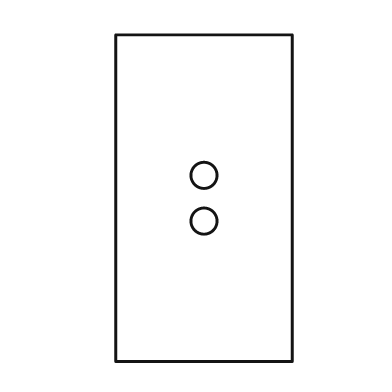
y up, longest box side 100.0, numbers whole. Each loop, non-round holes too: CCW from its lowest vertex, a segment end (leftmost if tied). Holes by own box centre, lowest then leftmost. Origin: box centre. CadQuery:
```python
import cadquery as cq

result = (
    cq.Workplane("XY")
    .moveTo(-27.0, -50.0)
    .lineTo(27.0, -50.0)
    .lineTo(27.0, 50.0)
    .lineTo(-27.0, 50.0)
    .close()
    .moveTo(0.0, -7.0)
    .circle(4.0)
    .moveTo(0.0, 7.0)
    .circle(4.0)
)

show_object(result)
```